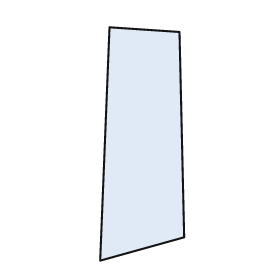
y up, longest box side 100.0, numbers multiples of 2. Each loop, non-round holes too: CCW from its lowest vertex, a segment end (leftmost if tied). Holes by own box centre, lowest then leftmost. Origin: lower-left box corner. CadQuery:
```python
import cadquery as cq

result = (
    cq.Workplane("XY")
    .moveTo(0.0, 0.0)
    .lineTo(36.0, 10.0)
    .lineTo(34.0, 98.0)
    .lineTo(4.0, 100.0)
    .close()
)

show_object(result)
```